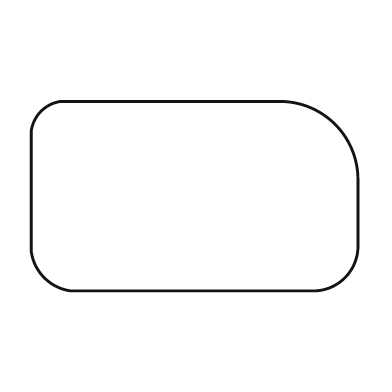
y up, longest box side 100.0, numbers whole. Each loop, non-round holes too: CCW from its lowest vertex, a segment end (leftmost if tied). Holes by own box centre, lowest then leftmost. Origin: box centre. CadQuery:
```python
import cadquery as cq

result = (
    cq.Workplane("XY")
    .moveTo(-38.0, -29.0)
    .lineTo(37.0, -29.0)
    .threePointArc((46.0, -25.0), (50.0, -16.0))
    .lineTo(50.0, 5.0)
    .threePointArc((43.0, 22.0), (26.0, 29.0))
    .lineTo(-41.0, 29.0)
    .threePointArc((-47.0, 26.0), (-50.0, 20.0))
    .lineTo(-50.0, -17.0)
    .threePointArc((-46.0, -25.0), (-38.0, -29.0))
    .close()
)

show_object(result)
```